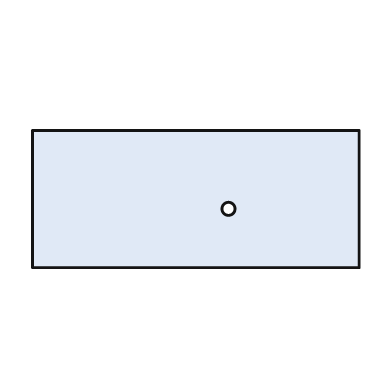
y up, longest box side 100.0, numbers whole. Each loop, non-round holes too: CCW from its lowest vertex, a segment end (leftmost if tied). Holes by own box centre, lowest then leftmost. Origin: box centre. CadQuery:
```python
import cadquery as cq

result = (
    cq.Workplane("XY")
    .moveTo(-50.0, -21.0)
    .lineTo(50.0, -21.0)
    .lineTo(50.0, 21.0)
    .lineTo(-50.0, 21.0)
    .close()
    .moveTo(10.0, -3.0)
    .circle(2.0)
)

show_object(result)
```